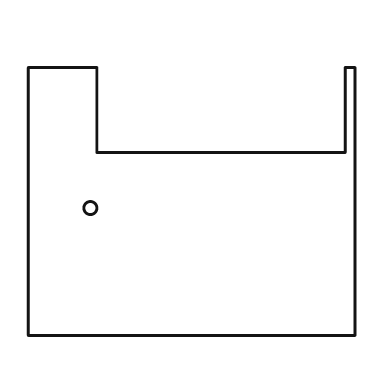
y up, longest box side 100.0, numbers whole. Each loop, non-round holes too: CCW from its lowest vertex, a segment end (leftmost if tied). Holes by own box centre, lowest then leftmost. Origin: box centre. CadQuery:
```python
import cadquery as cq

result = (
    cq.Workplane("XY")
    .moveTo(-50.0, -41.0)
    .lineTo(50.0, -41.0)
    .lineTo(50.0, 41.0)
    .lineTo(47.0, 41.0)
    .lineTo(47.0, 15.0)
    .lineTo(-29.0, 15.0)
    .lineTo(-29.0, 41.0)
    .lineTo(-50.0, 41.0)
    .close()
    .moveTo(-31.0, -2.0)
    .circle(2.0)
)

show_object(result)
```